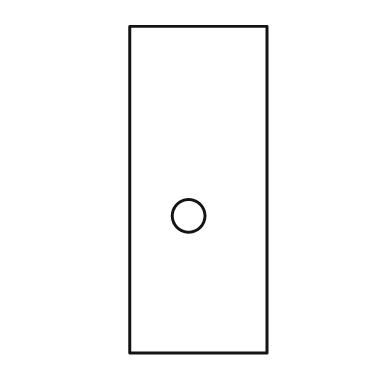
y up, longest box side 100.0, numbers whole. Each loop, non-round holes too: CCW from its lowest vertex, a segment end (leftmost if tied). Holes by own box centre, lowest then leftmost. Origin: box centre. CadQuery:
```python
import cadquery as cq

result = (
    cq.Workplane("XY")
    .moveTo(-21.0, -50.0)
    .lineTo(21.0, -50.0)
    .lineTo(21.0, 50.0)
    .lineTo(-21.0, 50.0)
    .close()
    .moveTo(-3.0, -8.0)
    .circle(5.0)
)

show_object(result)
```